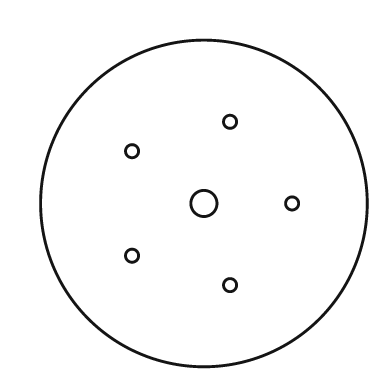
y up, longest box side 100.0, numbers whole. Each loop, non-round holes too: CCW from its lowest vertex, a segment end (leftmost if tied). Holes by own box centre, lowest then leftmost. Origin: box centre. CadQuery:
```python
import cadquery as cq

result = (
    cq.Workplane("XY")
    .moveTo(0.0, 0.0)
    .circle(50.0)
    .moveTo(8.0, -25.0)
    .circle(2.0)
    .moveTo(-22.0, -16.0)
    .circle(2.0)
    .moveTo(0.0, 0.0)
    .circle(4.0)
    .moveTo(27.0, 0.0)
    .circle(2.0)
    .moveTo(-22.0, 16.0)
    .circle(2.0)
    .moveTo(8.0, 25.0)
    .circle(2.0)
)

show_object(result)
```